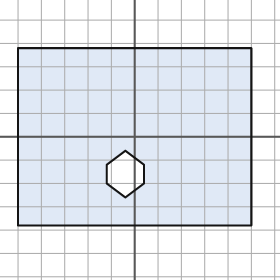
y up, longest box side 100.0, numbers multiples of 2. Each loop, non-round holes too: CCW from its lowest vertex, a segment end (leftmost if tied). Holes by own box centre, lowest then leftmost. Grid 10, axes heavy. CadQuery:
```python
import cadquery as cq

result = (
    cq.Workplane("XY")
    .moveTo(-50.0, -38.0)
    .lineTo(50.0, -38.0)
    .lineTo(50.0, 38.0)
    .lineTo(-50.0, 38.0)
    .close()
    .moveTo(-4.0, -26.0)
    .lineTo(4.0, -20.0)
    .lineTo(4.0, -12.0)
    .lineTo(-4.0, -6.0)
    .lineTo(-12.0, -12.0)
    .lineTo(-12.0, -20.0)
    .close()
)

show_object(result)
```